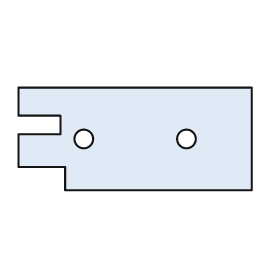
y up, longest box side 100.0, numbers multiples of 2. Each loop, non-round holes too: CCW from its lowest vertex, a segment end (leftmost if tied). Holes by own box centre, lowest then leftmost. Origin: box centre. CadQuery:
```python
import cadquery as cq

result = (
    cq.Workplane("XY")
    .moveTo(-30.0, -22.0)
    .lineTo(50.0, -22.0)
    .lineTo(50.0, 22.0)
    .lineTo(-50.0, 22.0)
    .lineTo(-50.0, 10.0)
    .lineTo(-32.0, 10.0)
    .lineTo(-32.0, 2.0)
    .lineTo(-50.0, 2.0)
    .lineTo(-50.0, -12.0)
    .lineTo(-30.0, -12.0)
    .close()
    .moveTo(-22.0, 0.0)
    .circle(4.0)
    .moveTo(22.0, 0.0)
    .circle(4.0)
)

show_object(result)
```